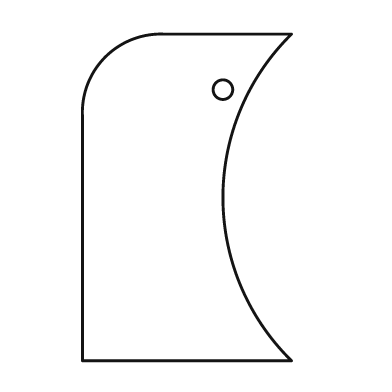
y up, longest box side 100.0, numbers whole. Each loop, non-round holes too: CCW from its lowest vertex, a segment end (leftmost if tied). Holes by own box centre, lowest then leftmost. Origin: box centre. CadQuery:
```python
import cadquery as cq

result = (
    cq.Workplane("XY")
    .moveTo(-32.0, -50.0)
    .lineTo(32.0, -50.0)
    .threePointArc((11.0, 0.0), (32.0, 50.0))
    .lineTo(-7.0, 50.0)
    .threePointArc((-25.0, 43.0), (-32.0, 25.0))
    .close()
    .moveTo(11.0, 33.0)
    .circle(3.0)
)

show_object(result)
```